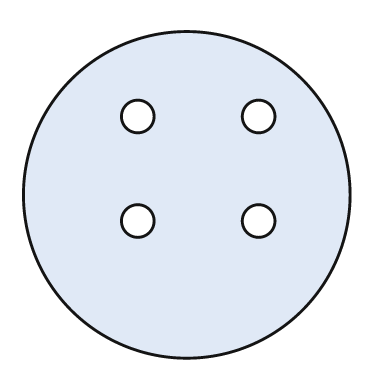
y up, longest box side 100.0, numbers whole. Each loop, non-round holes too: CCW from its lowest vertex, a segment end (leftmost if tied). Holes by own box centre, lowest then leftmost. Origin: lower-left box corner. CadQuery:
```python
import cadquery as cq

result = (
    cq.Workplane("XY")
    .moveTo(50.0, 50.0)
    .circle(50.0)
    .moveTo(35.0, 42.0)
    .circle(5.0)
    .moveTo(72.0, 42.0)
    .circle(5.0)
    .moveTo(35.0, 74.0)
    .circle(5.0)
    .moveTo(72.0, 74.0)
    .circle(5.0)
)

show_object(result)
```